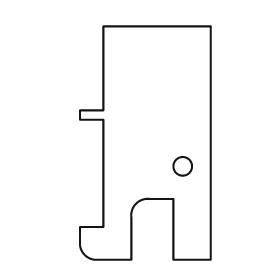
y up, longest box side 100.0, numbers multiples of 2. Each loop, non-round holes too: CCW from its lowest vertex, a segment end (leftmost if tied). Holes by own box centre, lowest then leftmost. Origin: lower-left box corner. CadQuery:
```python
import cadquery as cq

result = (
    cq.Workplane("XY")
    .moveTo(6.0, 0.0)
    .lineTo(22.0, 0.0)
    .lineTo(22.0, 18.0)
    .threePointArc((24.0, 24.0), (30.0, 26.0))
    .lineTo(40.0, 26.0)
    .lineTo(40.0, 0.0)
    .lineTo(56.0, 0.0)
    .lineTo(56.0, 100.0)
    .lineTo(10.0, 100.0)
    .lineTo(10.0, 64.0)
    .lineTo(0.0, 64.0)
    .lineTo(0.0, 60.0)
    .lineTo(10.0, 60.0)
    .lineTo(10.0, 14.0)
    .lineTo(0.0, 14.0)
    .lineTo(0.0, 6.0)
    .threePointArc((2.0, 2.0), (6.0, 0.0))
    .close()
    .moveTo(44.0, 40.0)
    .circle(4.0)
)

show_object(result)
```